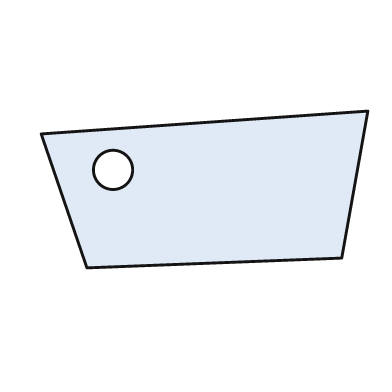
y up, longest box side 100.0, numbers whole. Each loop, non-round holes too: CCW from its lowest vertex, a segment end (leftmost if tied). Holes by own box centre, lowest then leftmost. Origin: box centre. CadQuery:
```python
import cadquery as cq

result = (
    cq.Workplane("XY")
    .moveTo(-36.0, -24.0)
    .lineTo(42.0, -21.0)
    .lineTo(50.0, 24.0)
    .lineTo(-50.0, 17.0)
    .close()
    .moveTo(-28.0, 6.0)
    .circle(6.0)
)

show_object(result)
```